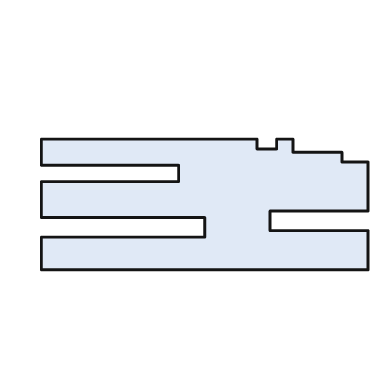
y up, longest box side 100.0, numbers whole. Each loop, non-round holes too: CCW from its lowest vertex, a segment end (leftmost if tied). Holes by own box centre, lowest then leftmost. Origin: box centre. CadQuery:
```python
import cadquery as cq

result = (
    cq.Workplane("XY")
    .moveTo(-50.0, -20.0)
    .lineTo(50.0, -20.0)
    .lineTo(50.0, -8.0)
    .lineTo(20.0, -8.0)
    .lineTo(20.0, -2.0)
    .lineTo(50.0, -2.0)
    .lineTo(50.0, 13.0)
    .lineTo(42.0, 13.0)
    .lineTo(42.0, 16.0)
    .lineTo(27.0, 16.0)
    .lineTo(27.0, 20.0)
    .lineTo(22.0, 20.0)
    .lineTo(22.0, 17.0)
    .lineTo(16.0, 17.0)
    .lineTo(16.0, 20.0)
    .lineTo(-50.0, 20.0)
    .lineTo(-50.0, 12.0)
    .lineTo(-8.0, 12.0)
    .lineTo(-8.0, 7.0)
    .lineTo(-50.0, 7.0)
    .lineTo(-50.0, -4.0)
    .lineTo(0.0, -4.0)
    .lineTo(0.0, -10.0)
    .lineTo(-50.0, -10.0)
    .close()
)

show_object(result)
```